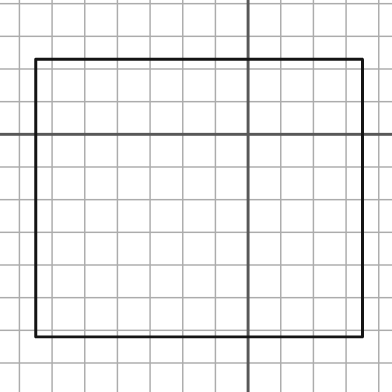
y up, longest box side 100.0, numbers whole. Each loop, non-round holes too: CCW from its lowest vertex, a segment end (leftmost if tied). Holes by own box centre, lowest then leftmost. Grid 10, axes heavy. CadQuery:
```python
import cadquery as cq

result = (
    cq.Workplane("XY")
    .moveTo(-65.0, -62.0)
    .lineTo(35.0, -62.0)
    .lineTo(35.0, 23.0)
    .lineTo(-65.0, 23.0)
    .close()
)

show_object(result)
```